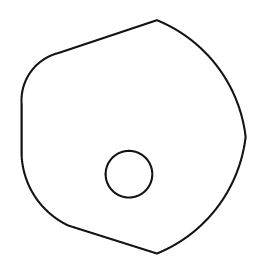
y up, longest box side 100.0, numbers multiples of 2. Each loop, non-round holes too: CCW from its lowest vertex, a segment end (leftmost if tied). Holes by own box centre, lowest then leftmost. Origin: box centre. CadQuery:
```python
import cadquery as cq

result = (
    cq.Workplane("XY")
    .moveTo(10.0, -50.0)
    .threePointArc((36.0, -30.0), (48.0, 0.0))
    .threePointArc((36.0, 30.0), (10.0, 50.0))
    .lineTo(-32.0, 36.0)
    .threePointArc((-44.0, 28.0), (-48.0, 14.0))
    .lineTo(-48.0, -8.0)
    .threePointArc((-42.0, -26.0), (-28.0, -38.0))
    .close()
    .moveTo(-2.0, -16.0)
    .circle(10.0)
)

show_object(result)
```